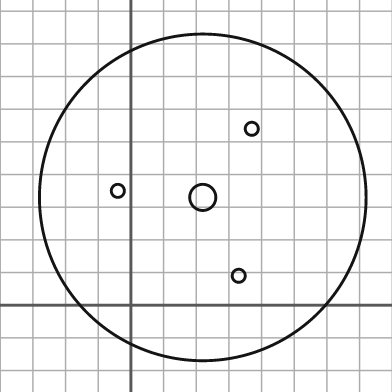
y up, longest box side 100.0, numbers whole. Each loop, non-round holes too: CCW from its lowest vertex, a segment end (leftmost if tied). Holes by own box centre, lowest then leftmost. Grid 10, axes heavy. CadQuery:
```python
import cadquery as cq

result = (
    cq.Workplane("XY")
    .moveTo(22.0, 33.0)
    .circle(50.0)
    .moveTo(33.0, 9.0)
    .circle(2.0)
    .moveTo(22.0, 33.0)
    .circle(4.0)
    .moveTo(-4.0, 35.0)
    .circle(2.0)
    .moveTo(37.0, 54.0)
    .circle(2.0)
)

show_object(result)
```